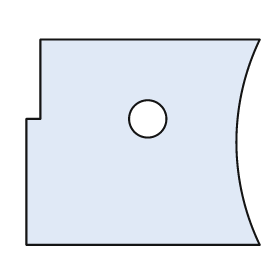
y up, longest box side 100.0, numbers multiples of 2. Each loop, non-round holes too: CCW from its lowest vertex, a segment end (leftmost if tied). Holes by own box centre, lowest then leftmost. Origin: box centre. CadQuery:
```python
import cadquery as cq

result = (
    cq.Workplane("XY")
    .moveTo(-50.0, -44.0)
    .lineTo(50.0, -44.0)
    .threePointArc((40.0, 0.0), (50.0, 44.0))
    .lineTo(-44.0, 44.0)
    .lineTo(-44.0, 10.0)
    .lineTo(-50.0, 10.0)
    .close()
    .moveTo(2.0, 10.0)
    .circle(8.0)
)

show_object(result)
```